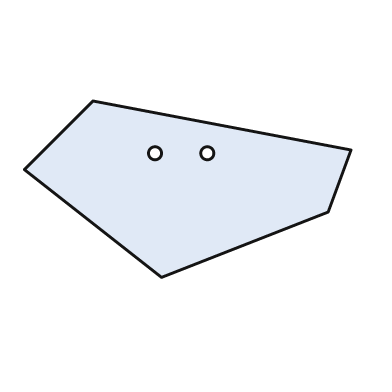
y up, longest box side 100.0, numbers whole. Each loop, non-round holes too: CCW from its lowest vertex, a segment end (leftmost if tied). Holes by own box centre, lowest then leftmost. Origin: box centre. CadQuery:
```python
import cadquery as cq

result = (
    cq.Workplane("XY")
    .moveTo(-8.0, -27.0)
    .lineTo(43.0, -7.0)
    .lineTo(50.0, 12.0)
    .lineTo(-29.0, 27.0)
    .lineTo(-50.0, 6.0)
    .close()
    .moveTo(-10.0, 11.0)
    .circle(2.0)
    .moveTo(6.0, 11.0)
    .circle(2.0)
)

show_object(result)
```